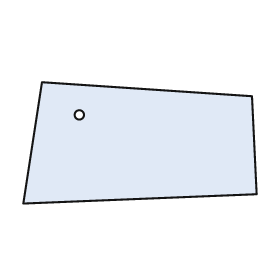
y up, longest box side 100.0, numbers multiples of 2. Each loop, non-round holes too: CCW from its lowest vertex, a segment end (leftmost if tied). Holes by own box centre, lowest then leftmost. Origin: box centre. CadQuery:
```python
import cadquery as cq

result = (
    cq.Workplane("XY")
    .moveTo(-50.0, -26.0)
    .lineTo(50.0, -22.0)
    .lineTo(48.0, 20.0)
    .lineTo(-42.0, 26.0)
    .close()
    .moveTo(-26.0, 12.0)
    .circle(2.0)
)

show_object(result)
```